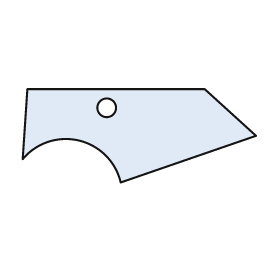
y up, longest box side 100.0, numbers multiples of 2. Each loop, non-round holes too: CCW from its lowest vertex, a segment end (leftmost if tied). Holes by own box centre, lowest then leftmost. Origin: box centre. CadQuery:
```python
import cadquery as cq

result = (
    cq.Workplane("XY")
    .moveTo(-8.0, -20.0)
    .lineTo(50.0, 0.0)
    .lineTo(28.0, 20.0)
    .lineTo(-48.0, 20.0)
    .lineTo(-50.0, -10.0)
    .threePointArc((-26.0, -2.0), (-8.0, -20.0))
    .close()
    .moveTo(-14.0, 12.0)
    .circle(4.0)
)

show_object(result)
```